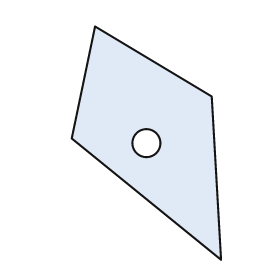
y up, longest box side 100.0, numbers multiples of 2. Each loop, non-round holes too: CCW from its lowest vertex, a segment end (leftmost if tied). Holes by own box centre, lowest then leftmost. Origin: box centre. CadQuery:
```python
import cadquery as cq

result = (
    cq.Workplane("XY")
    .moveTo(32.0, -50.0)
    .lineTo(28.0, 20.0)
    .lineTo(-22.0, 50.0)
    .lineTo(-32.0, 2.0)
    .close()
    .moveTo(0.0, 0.0)
    .circle(6.0)
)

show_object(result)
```